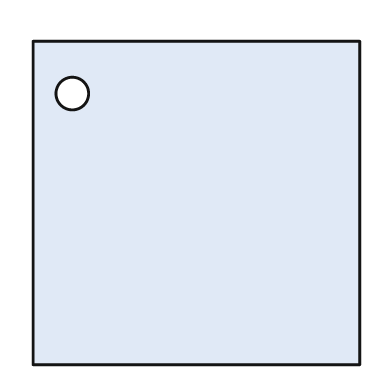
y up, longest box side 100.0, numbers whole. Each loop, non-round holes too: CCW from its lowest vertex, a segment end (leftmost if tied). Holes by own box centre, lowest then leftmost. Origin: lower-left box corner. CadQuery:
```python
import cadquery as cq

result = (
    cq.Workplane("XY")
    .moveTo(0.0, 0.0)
    .lineTo(100.0, 0.0)
    .lineTo(100.0, 99.0)
    .lineTo(0.0, 99.0)
    .close()
    .moveTo(12.0, 83.0)
    .circle(5.0)
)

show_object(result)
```